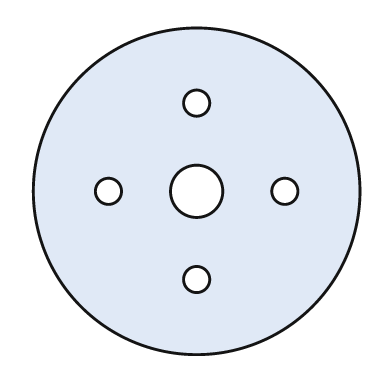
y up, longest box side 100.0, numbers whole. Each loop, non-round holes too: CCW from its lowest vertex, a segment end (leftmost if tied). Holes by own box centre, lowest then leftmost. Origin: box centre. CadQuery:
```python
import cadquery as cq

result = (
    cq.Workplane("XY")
    .moveTo(0.0, 0.0)
    .circle(50.0)
    .moveTo(0.0, -27.0)
    .circle(4.0)
    .moveTo(-27.0, 0.0)
    .circle(4.0)
    .moveTo(0.0, 0.0)
    .circle(8.0)
    .moveTo(27.0, 0.0)
    .circle(4.0)
    .moveTo(0.0, 27.0)
    .circle(4.0)
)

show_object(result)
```